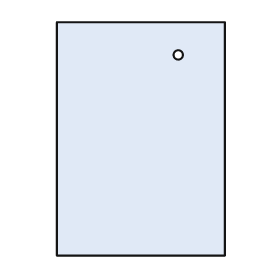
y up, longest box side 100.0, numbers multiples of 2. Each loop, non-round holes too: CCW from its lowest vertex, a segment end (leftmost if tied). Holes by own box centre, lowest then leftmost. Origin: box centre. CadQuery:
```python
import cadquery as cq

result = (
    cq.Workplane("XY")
    .moveTo(-36.0, -50.0)
    .lineTo(36.0, -50.0)
    .lineTo(36.0, 50.0)
    .lineTo(-36.0, 50.0)
    .close()
    .moveTo(16.0, 36.0)
    .circle(2.0)
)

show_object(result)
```